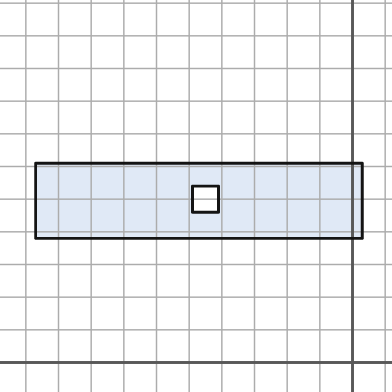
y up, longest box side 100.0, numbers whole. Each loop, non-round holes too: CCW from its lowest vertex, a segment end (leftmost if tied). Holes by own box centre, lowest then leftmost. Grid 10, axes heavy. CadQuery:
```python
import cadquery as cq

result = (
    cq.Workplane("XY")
    .moveTo(-97.0, 38.0)
    .lineTo(3.0, 38.0)
    .lineTo(3.0, 61.0)
    .lineTo(-97.0, 61.0)
    .close()
    .moveTo(-49.0, 46.0)
    .lineTo(-41.0, 46.0)
    .lineTo(-41.0, 54.0)
    .lineTo(-49.0, 54.0)
    .close()
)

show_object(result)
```